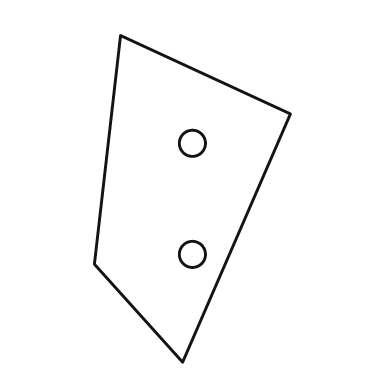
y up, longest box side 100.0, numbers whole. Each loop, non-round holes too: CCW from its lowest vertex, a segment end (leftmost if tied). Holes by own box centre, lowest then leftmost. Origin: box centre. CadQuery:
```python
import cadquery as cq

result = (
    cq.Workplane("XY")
    .moveTo(-3.0, -50.0)
    .lineTo(30.0, 26.0)
    .lineTo(-22.0, 50.0)
    .lineTo(-30.0, -20.0)
    .close()
    .moveTo(0.0, -17.0)
    .circle(4.0)
    .moveTo(0.0, 17.0)
    .circle(4.0)
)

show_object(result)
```